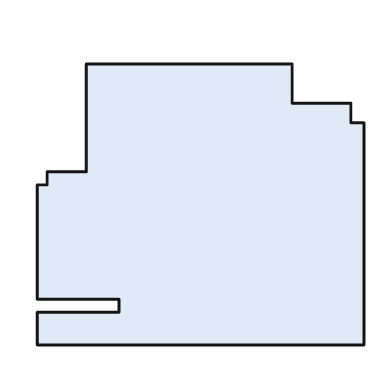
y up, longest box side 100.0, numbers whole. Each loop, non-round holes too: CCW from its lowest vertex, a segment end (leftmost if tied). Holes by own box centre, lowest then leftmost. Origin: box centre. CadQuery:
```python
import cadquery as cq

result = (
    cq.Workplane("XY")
    .moveTo(-50.0, -43.0)
    .lineTo(50.0, -43.0)
    .lineTo(50.0, 25.0)
    .lineTo(46.0, 25.0)
    .lineTo(46.0, 31.0)
    .lineTo(28.0, 31.0)
    .lineTo(28.0, 43.0)
    .lineTo(-35.0, 43.0)
    .lineTo(-35.0, 10.0)
    .lineTo(-47.0, 10.0)
    .lineTo(-47.0, 6.0)
    .lineTo(-50.0, 6.0)
    .lineTo(-50.0, -29.0)
    .lineTo(-25.0, -29.0)
    .lineTo(-25.0, -33.0)
    .lineTo(-50.0, -33.0)
    .close()
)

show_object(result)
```